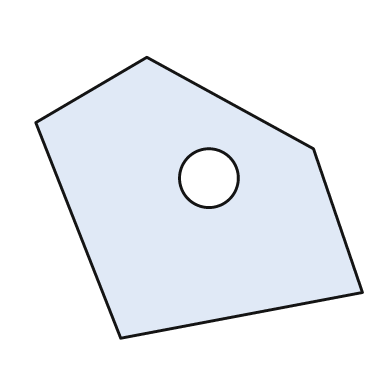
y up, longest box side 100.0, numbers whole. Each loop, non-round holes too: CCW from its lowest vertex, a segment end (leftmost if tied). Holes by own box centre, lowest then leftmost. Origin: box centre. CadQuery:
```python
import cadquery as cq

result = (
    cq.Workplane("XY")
    .moveTo(-24.0, -43.0)
    .lineTo(50.0, -29.0)
    .lineTo(35.0, 15.0)
    .lineTo(-16.0, 43.0)
    .lineTo(-50.0, 23.0)
    .close()
    .moveTo(3.0, 6.0)
    .circle(9.0)
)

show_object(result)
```